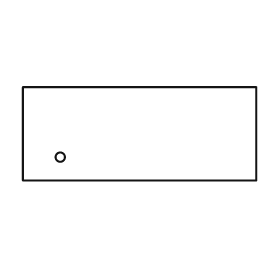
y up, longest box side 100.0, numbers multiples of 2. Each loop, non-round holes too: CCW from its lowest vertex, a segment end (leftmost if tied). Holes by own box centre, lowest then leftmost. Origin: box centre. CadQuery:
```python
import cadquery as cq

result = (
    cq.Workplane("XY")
    .moveTo(-50.0, -20.0)
    .lineTo(50.0, -20.0)
    .lineTo(50.0, 20.0)
    .lineTo(-50.0, 20.0)
    .close()
    .moveTo(-34.0, -10.0)
    .circle(2.0)
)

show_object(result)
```